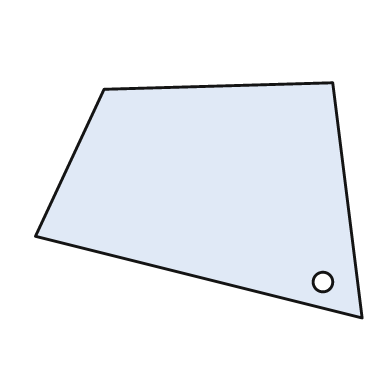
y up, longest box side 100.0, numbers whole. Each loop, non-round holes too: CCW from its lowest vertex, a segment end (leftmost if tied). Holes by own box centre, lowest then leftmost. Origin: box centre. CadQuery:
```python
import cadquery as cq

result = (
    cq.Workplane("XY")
    .moveTo(50.0, -36.0)
    .lineTo(41.0, 36.0)
    .lineTo(-29.0, 34.0)
    .lineTo(-50.0, -11.0)
    .close()
    .moveTo(38.0, -25.0)
    .circle(3.0)
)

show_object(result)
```